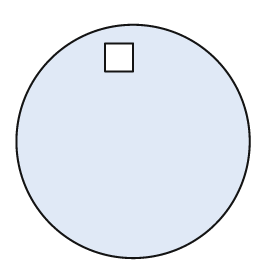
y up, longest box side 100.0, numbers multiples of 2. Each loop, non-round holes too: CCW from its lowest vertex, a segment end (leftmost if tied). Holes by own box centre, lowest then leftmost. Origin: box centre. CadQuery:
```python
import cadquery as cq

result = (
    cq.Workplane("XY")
    .moveTo(0.0, 0.0)
    .circle(50.0)
    .moveTo(-12.0, 30.0)
    .lineTo(0.0, 30.0)
    .lineTo(0.0, 42.0)
    .lineTo(-12.0, 42.0)
    .close()
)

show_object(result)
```